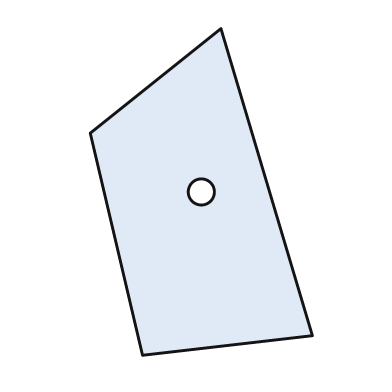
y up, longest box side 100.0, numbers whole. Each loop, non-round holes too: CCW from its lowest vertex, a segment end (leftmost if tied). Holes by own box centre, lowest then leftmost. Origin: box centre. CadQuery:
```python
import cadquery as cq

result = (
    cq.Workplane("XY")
    .moveTo(-18.0, -50.0)
    .lineTo(34.0, -44.0)
    .lineTo(6.0, 50.0)
    .lineTo(-34.0, 18.0)
    .close()
    .moveTo(0.0, 0.0)
    .circle(4.0)
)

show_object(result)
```